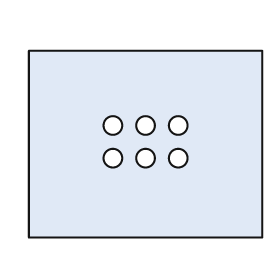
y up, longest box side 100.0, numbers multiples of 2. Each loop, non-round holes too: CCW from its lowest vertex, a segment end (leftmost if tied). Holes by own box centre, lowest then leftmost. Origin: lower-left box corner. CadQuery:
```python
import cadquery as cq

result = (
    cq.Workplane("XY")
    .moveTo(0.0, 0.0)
    .lineTo(100.0, 0.0)
    .lineTo(100.0, 80.0)
    .lineTo(0.0, 80.0)
    .close()
    .moveTo(36.0, 34.0)
    .circle(4.0)
    .moveTo(50.0, 34.0)
    .circle(4.0)
    .moveTo(64.0, 34.0)
    .circle(4.0)
    .moveTo(36.0, 48.0)
    .circle(4.0)
    .moveTo(50.0, 48.0)
    .circle(4.0)
    .moveTo(64.0, 48.0)
    .circle(4.0)
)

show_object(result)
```